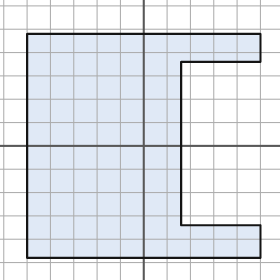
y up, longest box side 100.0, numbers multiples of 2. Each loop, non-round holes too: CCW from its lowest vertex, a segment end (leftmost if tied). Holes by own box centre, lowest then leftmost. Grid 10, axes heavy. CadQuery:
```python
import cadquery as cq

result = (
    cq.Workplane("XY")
    .moveTo(-50.0, -48.0)
    .lineTo(50.0, -48.0)
    .lineTo(50.0, -34.0)
    .lineTo(16.0, -34.0)
    .lineTo(16.0, 36.0)
    .lineTo(50.0, 36.0)
    .lineTo(50.0, 48.0)
    .lineTo(-50.0, 48.0)
    .close()
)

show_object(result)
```